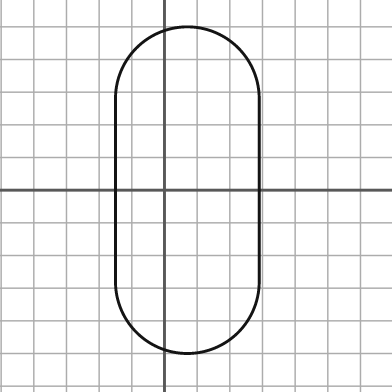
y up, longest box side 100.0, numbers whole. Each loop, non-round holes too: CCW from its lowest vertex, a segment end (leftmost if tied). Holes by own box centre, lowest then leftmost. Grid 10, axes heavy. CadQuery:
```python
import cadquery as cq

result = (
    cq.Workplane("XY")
    .moveTo(-15.0, -28.0)
    .threePointArc((7.0, -50.0), (29.0, -28.0))
    .lineTo(29.0, 28.0)
    .threePointArc((7.0, 50.0), (-15.0, 28.0))
    .close()
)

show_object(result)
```